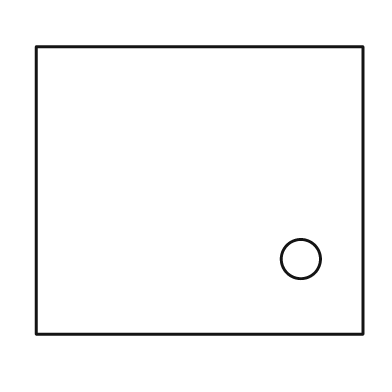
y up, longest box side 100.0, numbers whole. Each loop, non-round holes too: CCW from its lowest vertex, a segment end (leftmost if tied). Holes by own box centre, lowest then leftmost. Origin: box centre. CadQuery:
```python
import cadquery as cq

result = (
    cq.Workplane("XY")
    .moveTo(-50.0, -44.0)
    .lineTo(50.0, -44.0)
    .lineTo(50.0, 44.0)
    .lineTo(-50.0, 44.0)
    .close()
    .moveTo(31.0, -21.0)
    .circle(6.0)
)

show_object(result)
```